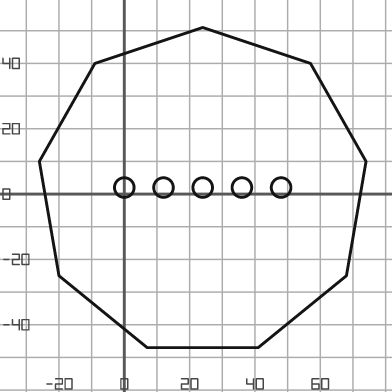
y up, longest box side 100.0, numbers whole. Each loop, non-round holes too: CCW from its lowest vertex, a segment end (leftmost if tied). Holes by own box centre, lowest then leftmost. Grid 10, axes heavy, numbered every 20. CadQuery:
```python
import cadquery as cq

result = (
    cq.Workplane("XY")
    .moveTo(7.0, -47.0)
    .lineTo(41.0, -47.0)
    .lineTo(68.0, -25.0)
    .lineTo(74.0, 10.0)
    .lineTo(57.0, 40.0)
    .lineTo(24.0, 51.0)
    .lineTo(-9.0, 40.0)
    .lineTo(-26.0, 10.0)
    .lineTo(-20.0, -25.0)
    .close()
    .moveTo(0.0, 2.0)
    .circle(3.0)
    .moveTo(12.0, 2.0)
    .circle(3.0)
    .moveTo(24.0, 2.0)
    .circle(3.0)
    .moveTo(36.0, 2.0)
    .circle(3.0)
    .moveTo(48.0, 2.0)
    .circle(3.0)
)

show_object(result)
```